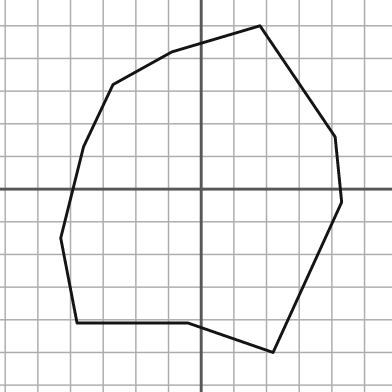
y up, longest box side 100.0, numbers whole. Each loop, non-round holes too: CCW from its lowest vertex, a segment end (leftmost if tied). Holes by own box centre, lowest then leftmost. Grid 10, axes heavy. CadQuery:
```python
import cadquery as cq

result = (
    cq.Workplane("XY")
    .moveTo(22.0, -50.0)
    .lineTo(43.0, -4.0)
    .lineTo(41.0, 16.0)
    .lineTo(18.0, 50.0)
    .lineTo(-9.0, 42.0)
    .lineTo(-27.0, 32.0)
    .lineTo(-36.0, 13.0)
    .lineTo(-43.0, -15.0)
    .lineTo(-38.0, -41.0)
    .lineTo(-4.0, -41.0)
    .close()
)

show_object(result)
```